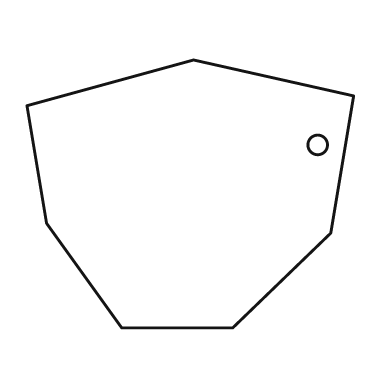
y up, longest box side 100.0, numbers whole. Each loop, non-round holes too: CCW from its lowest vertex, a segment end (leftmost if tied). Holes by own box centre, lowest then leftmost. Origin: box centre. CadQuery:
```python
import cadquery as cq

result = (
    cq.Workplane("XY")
    .moveTo(-21.0, -41.0)
    .lineTo(13.0, -41.0)
    .lineTo(43.0, -12.0)
    .lineTo(50.0, 30.0)
    .lineTo(1.0, 41.0)
    .lineTo(-50.0, 27.0)
    .lineTo(-44.0, -9.0)
    .close()
    .moveTo(39.0, 15.0)
    .circle(3.0)
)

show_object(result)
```